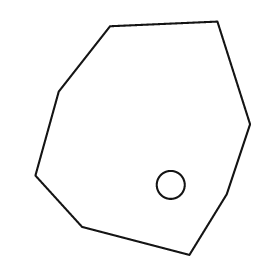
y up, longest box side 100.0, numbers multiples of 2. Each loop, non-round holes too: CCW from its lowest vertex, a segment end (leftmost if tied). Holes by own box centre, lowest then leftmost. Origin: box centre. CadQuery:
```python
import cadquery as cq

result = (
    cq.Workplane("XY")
    .moveTo(20.0, -50.0)
    .lineTo(36.0, -24.0)
    .lineTo(46.0, 6.0)
    .lineTo(32.0, 50.0)
    .lineTo(-14.0, 48.0)
    .lineTo(-36.0, 20.0)
    .lineTo(-46.0, -16.0)
    .lineTo(-26.0, -38.0)
    .close()
    .moveTo(12.0, -20.0)
    .circle(6.0)
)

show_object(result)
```